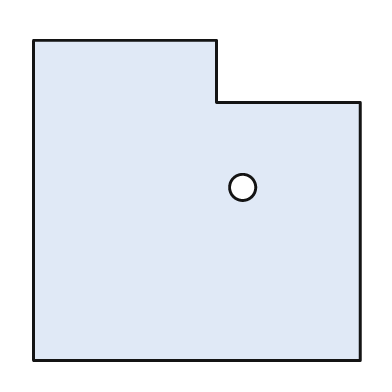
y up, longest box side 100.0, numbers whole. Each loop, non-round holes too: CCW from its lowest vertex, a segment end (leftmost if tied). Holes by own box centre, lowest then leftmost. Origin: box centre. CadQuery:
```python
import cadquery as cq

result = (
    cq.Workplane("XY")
    .moveTo(-50.0, -49.0)
    .lineTo(50.0, -49.0)
    .lineTo(50.0, 30.0)
    .lineTo(6.0, 30.0)
    .lineTo(6.0, 49.0)
    .lineTo(-50.0, 49.0)
    .close()
    .moveTo(14.0, 4.0)
    .circle(4.0)
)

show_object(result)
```